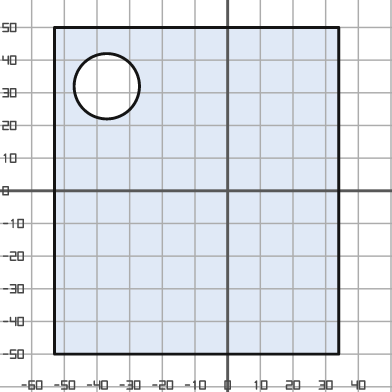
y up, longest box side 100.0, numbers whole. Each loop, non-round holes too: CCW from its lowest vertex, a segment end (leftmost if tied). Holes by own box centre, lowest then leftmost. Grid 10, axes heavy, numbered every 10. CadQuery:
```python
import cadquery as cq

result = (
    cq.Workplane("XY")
    .moveTo(-53.0, -50.0)
    .lineTo(34.0, -50.0)
    .lineTo(34.0, 50.0)
    .lineTo(-53.0, 50.0)
    .close()
    .moveTo(-37.0, 32.0)
    .circle(10.0)
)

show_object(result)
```